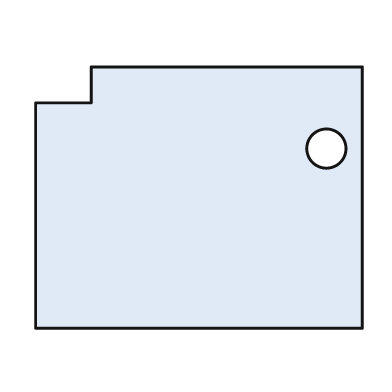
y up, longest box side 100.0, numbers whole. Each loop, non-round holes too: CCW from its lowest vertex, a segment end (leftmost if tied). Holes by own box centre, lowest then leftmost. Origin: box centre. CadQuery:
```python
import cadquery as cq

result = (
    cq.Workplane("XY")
    .moveTo(-50.0, -40.0)
    .lineTo(50.0, -40.0)
    .lineTo(50.0, 40.0)
    .lineTo(-33.0, 40.0)
    .lineTo(-33.0, 29.0)
    .lineTo(-50.0, 29.0)
    .close()
    .moveTo(39.0, 15.0)
    .circle(6.0)
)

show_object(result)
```